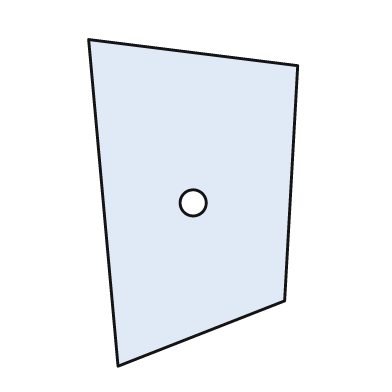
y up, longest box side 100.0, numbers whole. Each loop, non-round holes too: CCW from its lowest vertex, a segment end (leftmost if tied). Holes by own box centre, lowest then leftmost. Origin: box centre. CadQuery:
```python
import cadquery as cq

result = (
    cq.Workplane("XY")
    .moveTo(-23.0, -50.0)
    .lineTo(28.0, -30.0)
    .lineTo(32.0, 42.0)
    .lineTo(-32.0, 50.0)
    .close()
    .moveTo(0.0, 0.0)
    .circle(4.0)
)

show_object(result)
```